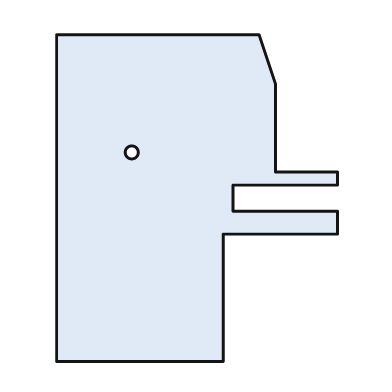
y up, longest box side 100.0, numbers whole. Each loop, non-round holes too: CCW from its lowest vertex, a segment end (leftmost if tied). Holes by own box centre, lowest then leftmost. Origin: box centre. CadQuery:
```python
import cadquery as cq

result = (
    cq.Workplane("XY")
    .moveTo(-43.0, -50.0)
    .lineTo(8.0, -50.0)
    .lineTo(8.0, -11.0)
    .lineTo(43.0, -11.0)
    .lineTo(43.0, -4.0)
    .lineTo(11.0, -4.0)
    .lineTo(11.0, 4.0)
    .lineTo(43.0, 4.0)
    .lineTo(43.0, 8.0)
    .lineTo(24.0, 8.0)
    .lineTo(24.0, 35.0)
    .lineTo(19.0, 50.0)
    .lineTo(-43.0, 50.0)
    .close()
    .moveTo(-20.0, 14.0)
    .circle(2.0)
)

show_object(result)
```